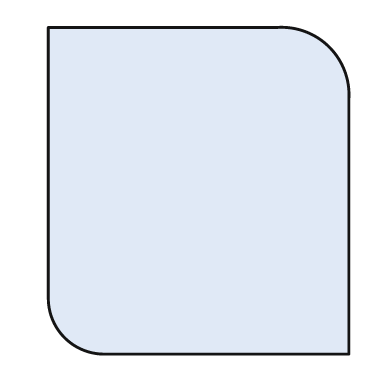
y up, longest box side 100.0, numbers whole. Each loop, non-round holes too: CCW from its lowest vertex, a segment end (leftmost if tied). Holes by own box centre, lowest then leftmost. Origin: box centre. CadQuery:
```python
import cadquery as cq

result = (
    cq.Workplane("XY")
    .moveTo(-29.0, -50.0)
    .lineTo(46.0, -50.0)
    .lineTo(46.0, 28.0)
    .threePointArc((40.0, 44.0), (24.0, 50.0))
    .lineTo(-46.0, 50.0)
    .lineTo(-46.0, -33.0)
    .threePointArc((-41.0, -45.0), (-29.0, -50.0))
    .close()
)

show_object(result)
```